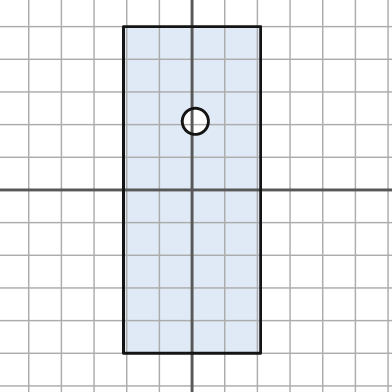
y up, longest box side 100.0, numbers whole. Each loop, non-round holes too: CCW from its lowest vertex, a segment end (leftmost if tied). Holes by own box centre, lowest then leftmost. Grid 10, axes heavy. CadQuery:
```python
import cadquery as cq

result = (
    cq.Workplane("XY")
    .moveTo(-21.0, -50.0)
    .lineTo(21.0, -50.0)
    .lineTo(21.0, 50.0)
    .lineTo(-21.0, 50.0)
    .close()
    .moveTo(1.0, 21.0)
    .circle(4.0)
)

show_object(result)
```